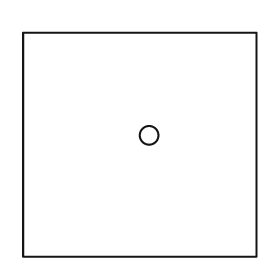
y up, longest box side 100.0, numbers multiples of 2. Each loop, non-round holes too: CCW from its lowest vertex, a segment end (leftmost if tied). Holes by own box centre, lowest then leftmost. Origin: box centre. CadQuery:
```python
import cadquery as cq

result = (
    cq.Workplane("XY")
    .moveTo(-50.0, -48.0)
    .lineTo(50.0, -48.0)
    .lineTo(50.0, 48.0)
    .lineTo(-50.0, 48.0)
    .close()
    .moveTo(4.0, 4.0)
    .circle(4.0)
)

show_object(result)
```